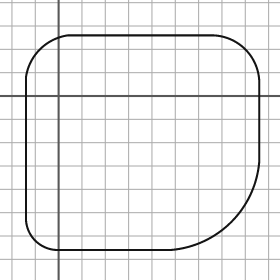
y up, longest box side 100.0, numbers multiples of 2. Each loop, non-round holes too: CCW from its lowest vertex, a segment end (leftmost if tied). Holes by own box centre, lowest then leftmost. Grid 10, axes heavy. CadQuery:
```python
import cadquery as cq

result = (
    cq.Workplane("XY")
    .moveTo(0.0, -66.0)
    .lineTo(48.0, -66.0)
    .threePointArc((74.0, -54.0), (86.0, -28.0))
    .lineTo(86.0, 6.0)
    .threePointArc((80.0, 20.0), (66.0, 26.0))
    .lineTo(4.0, 26.0)
    .threePointArc((-8.0, 20.0), (-14.0, 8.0))
    .lineTo(-14.0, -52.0)
    .threePointArc((-10.0, -62.0), (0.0, -66.0))
    .close()
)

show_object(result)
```